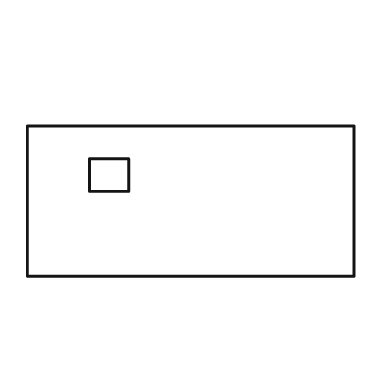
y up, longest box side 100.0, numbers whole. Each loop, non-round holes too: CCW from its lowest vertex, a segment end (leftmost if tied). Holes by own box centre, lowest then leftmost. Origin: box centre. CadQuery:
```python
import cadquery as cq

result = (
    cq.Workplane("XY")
    .moveTo(-50.0, -23.0)
    .lineTo(50.0, -23.0)
    .lineTo(50.0, 23.0)
    .lineTo(-50.0, 23.0)
    .close()
    .moveTo(-31.0, 3.0)
    .lineTo(-19.0, 3.0)
    .lineTo(-19.0, 13.0)
    .lineTo(-31.0, 13.0)
    .close()
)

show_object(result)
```